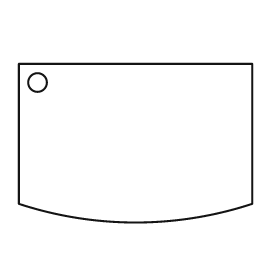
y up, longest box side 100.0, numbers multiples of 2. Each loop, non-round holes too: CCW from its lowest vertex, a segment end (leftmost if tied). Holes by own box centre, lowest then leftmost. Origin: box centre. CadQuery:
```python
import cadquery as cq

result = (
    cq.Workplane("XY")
    .moveTo(-50.0, -26.0)
    .threePointArc((0.0, -34.0), (50.0, -26.0))
    .lineTo(50.0, 34.0)
    .lineTo(-50.0, 34.0)
    .close()
    .moveTo(-42.0, 26.0)
    .circle(4.0)
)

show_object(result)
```